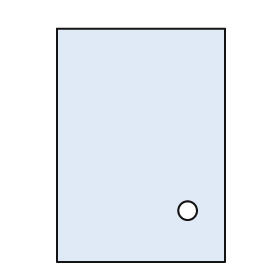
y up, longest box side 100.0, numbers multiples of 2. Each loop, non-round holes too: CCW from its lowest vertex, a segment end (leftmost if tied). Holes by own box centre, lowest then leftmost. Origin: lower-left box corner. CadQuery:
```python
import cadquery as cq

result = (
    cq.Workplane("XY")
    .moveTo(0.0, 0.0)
    .lineTo(72.0, 0.0)
    .lineTo(72.0, 100.0)
    .lineTo(0.0, 100.0)
    .close()
    .moveTo(56.0, 22.0)
    .circle(4.0)
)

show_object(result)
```